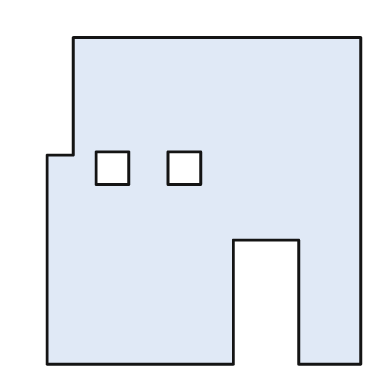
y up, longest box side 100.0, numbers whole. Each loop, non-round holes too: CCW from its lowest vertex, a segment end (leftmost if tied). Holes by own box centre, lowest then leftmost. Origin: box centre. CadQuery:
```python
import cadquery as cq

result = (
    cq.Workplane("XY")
    .moveTo(-48.0, -50.0)
    .lineTo(9.0, -50.0)
    .lineTo(9.0, -12.0)
    .lineTo(29.0, -12.0)
    .lineTo(29.0, -50.0)
    .lineTo(48.0, -50.0)
    .lineTo(48.0, 50.0)
    .lineTo(-40.0, 50.0)
    .lineTo(-40.0, 14.0)
    .lineTo(-48.0, 14.0)
    .close()
    .moveTo(-33.0, 5.0)
    .lineTo(-23.0, 5.0)
    .lineTo(-23.0, 15.0)
    .lineTo(-33.0, 15.0)
    .close()
    .moveTo(-11.0, 5.0)
    .lineTo(-1.0, 5.0)
    .lineTo(-1.0, 15.0)
    .lineTo(-11.0, 15.0)
    .close()
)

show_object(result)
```